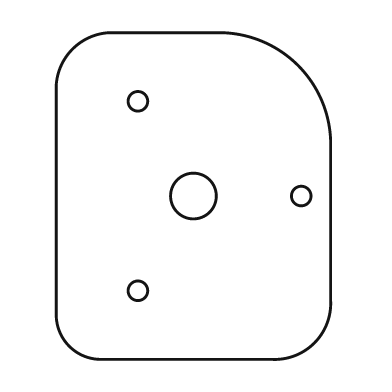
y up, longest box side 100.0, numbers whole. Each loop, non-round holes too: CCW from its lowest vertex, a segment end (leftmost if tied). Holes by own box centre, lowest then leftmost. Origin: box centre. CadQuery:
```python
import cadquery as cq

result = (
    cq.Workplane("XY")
    .moveTo(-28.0, -50.0)
    .lineTo(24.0, -50.0)
    .threePointArc((37.0, -45.0), (42.0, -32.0))
    .lineTo(42.0, 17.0)
    .threePointArc((32.0, 40.0), (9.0, 50.0))
    .lineTo(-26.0, 50.0)
    .threePointArc((-37.0, 45.0), (-42.0, 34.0))
    .lineTo(-42.0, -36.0)
    .threePointArc((-38.0, -46.0), (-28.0, -50.0))
    .close()
    .moveTo(-17.0, -29.0)
    .circle(3.0)
    .moveTo(0.0, 0.0)
    .circle(7.0)
    .moveTo(33.0, 0.0)
    .circle(3.0)
    .moveTo(-17.0, 29.0)
    .circle(3.0)
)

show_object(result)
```